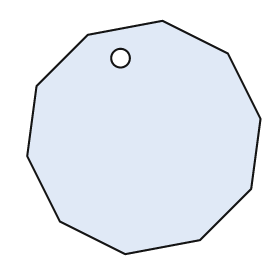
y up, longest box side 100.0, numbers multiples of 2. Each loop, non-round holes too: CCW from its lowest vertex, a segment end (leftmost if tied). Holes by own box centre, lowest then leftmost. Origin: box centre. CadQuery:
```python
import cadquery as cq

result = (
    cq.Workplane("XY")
    .moveTo(-8.0, -50.0)
    .lineTo(24.0, -44.0)
    .lineTo(46.0, -22.0)
    .lineTo(50.0, 8.0)
    .lineTo(36.0, 36.0)
    .lineTo(8.0, 50.0)
    .lineTo(-24.0, 44.0)
    .lineTo(-46.0, 22.0)
    .lineTo(-50.0, -8.0)
    .lineTo(-36.0, -36.0)
    .close()
    .moveTo(-10.0, 34.0)
    .circle(4.0)
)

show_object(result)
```